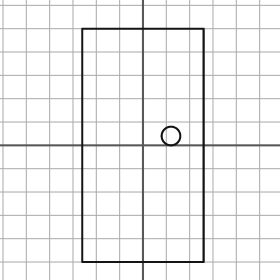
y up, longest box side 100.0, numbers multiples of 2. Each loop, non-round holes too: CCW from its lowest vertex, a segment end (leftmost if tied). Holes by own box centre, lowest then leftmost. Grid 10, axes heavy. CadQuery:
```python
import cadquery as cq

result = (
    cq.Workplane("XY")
    .moveTo(-26.0, -50.0)
    .lineTo(26.0, -50.0)
    .lineTo(26.0, 50.0)
    .lineTo(-26.0, 50.0)
    .close()
    .moveTo(12.0, 4.0)
    .circle(4.0)
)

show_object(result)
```